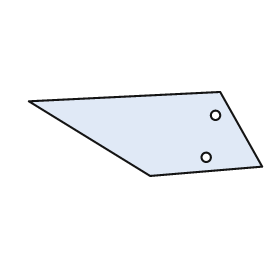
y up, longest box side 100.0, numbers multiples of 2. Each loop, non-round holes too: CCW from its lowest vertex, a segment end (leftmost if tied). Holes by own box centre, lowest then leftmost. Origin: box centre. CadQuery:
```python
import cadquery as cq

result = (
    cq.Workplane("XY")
    .moveTo(2.0, -18.0)
    .lineTo(50.0, -14.0)
    .lineTo(32.0, 18.0)
    .lineTo(-50.0, 14.0)
    .close()
    .moveTo(26.0, -10.0)
    .circle(2.0)
    .moveTo(30.0, 8.0)
    .circle(2.0)
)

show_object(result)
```